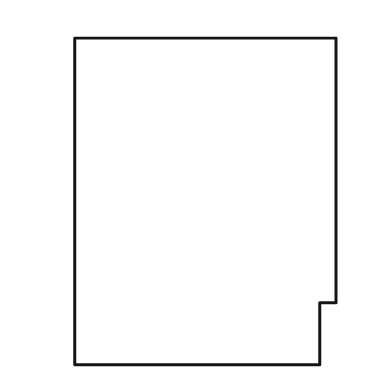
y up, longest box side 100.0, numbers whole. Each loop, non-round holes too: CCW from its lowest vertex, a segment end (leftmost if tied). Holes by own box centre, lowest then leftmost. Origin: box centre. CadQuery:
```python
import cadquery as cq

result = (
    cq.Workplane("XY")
    .moveTo(-40.0, -50.0)
    .lineTo(35.0, -50.0)
    .lineTo(35.0, -31.0)
    .lineTo(40.0, -31.0)
    .lineTo(40.0, 50.0)
    .lineTo(-40.0, 50.0)
    .close()
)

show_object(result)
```